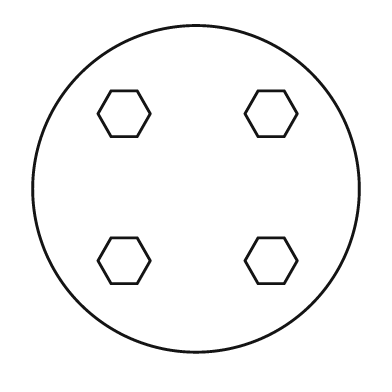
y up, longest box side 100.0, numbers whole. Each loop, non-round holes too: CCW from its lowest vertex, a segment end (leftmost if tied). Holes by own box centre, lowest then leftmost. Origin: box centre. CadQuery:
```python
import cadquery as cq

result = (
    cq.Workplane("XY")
    .moveTo(0.0, 0.0)
    .circle(50.0)
    .moveTo(-26.0, -29.0)
    .lineTo(-18.0, -29.0)
    .lineTo(-14.0, -22.0)
    .lineTo(-18.0, -15.0)
    .lineTo(-26.0, -15.0)
    .lineTo(-30.0, -22.0)
    .close()
    .moveTo(19.0, -29.0)
    .lineTo(27.0, -29.0)
    .lineTo(31.0, -22.0)
    .lineTo(27.0, -15.0)
    .lineTo(19.0, -15.0)
    .lineTo(15.0, -22.0)
    .close()
    .moveTo(-26.0, 16.0)
    .lineTo(-18.0, 16.0)
    .lineTo(-14.0, 23.0)
    .lineTo(-18.0, 30.0)
    .lineTo(-26.0, 30.0)
    .lineTo(-30.0, 23.0)
    .close()
    .moveTo(19.0, 16.0)
    .lineTo(27.0, 16.0)
    .lineTo(31.0, 23.0)
    .lineTo(27.0, 30.0)
    .lineTo(19.0, 30.0)
    .lineTo(15.0, 23.0)
    .close()
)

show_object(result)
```